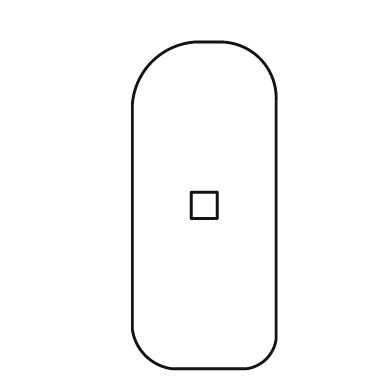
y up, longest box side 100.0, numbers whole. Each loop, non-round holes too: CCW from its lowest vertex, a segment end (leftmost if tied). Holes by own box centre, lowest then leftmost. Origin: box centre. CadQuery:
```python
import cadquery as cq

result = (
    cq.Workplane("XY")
    .moveTo(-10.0, -50.0)
    .lineTo(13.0, -50.0)
    .threePointArc((19.0, -47.0), (22.0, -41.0))
    .lineTo(22.0, 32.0)
    .threePointArc((17.0, 45.0), (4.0, 50.0))
    .lineTo(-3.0, 50.0)
    .threePointArc((-16.0, 44.0), (-22.0, 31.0))
    .lineTo(-22.0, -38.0)
    .threePointArc((-18.0, -46.0), (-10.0, -50.0))
    .close()
    .moveTo(-4.0, -4.0)
    .lineTo(4.0, -4.0)
    .lineTo(4.0, 4.0)
    .lineTo(-4.0, 4.0)
    .close()
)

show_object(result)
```